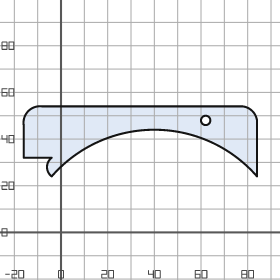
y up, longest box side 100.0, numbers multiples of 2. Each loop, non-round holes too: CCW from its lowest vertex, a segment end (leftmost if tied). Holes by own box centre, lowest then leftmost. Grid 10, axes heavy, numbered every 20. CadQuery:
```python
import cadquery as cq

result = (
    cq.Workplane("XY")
    .moveTo(-4.0, 24.0)
    .threePointArc((40.0, 44.0), (84.0, 24.0))
    .lineTo(84.0, 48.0)
    .threePointArc((82.0, 52.0), (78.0, 54.0))
    .lineTo(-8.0, 54.0)
    .threePointArc((-14.0, 52.0), (-16.0, 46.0))
    .lineTo(-16.0, 32.0)
    .lineTo(-4.0, 32.0)
    .threePointArc((-6.0, 28.0), (-4.0, 24.0))
    .close()
    .moveTo(62.0, 48.0)
    .circle(2.0)
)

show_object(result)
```